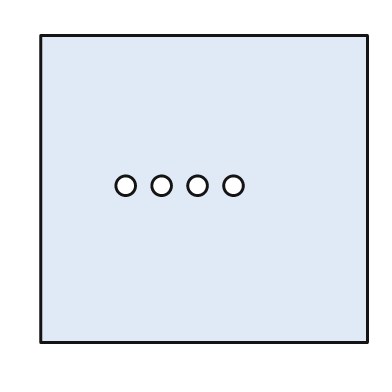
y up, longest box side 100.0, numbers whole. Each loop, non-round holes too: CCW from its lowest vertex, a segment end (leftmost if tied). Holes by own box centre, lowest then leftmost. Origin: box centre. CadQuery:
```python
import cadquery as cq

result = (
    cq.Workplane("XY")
    .moveTo(-50.0, -47.0)
    .lineTo(50.0, -47.0)
    .lineTo(50.0, 47.0)
    .lineTo(-50.0, 47.0)
    .close()
    .moveTo(-24.0, 1.0)
    .circle(3.0)
    .moveTo(-13.0, 1.0)
    .circle(3.0)
    .moveTo(-2.0, 1.0)
    .circle(3.0)
    .moveTo(9.0, 1.0)
    .circle(3.0)
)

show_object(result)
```